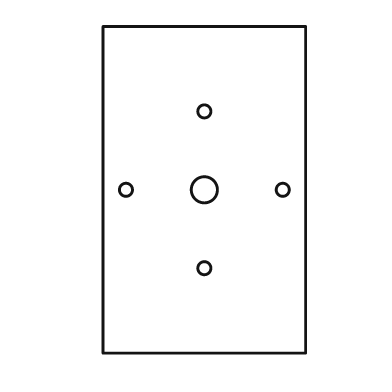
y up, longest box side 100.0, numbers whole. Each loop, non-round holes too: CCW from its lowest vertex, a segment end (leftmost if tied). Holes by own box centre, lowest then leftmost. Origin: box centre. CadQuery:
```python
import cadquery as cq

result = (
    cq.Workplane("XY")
    .moveTo(-31.0, -50.0)
    .lineTo(31.0, -50.0)
    .lineTo(31.0, 50.0)
    .lineTo(-31.0, 50.0)
    .close()
    .moveTo(0.0, -24.0)
    .circle(2.0)
    .moveTo(-24.0, 0.0)
    .circle(2.0)
    .moveTo(0.0, 0.0)
    .circle(4.0)
    .moveTo(24.0, 0.0)
    .circle(2.0)
    .moveTo(0.0, 24.0)
    .circle(2.0)
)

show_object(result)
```